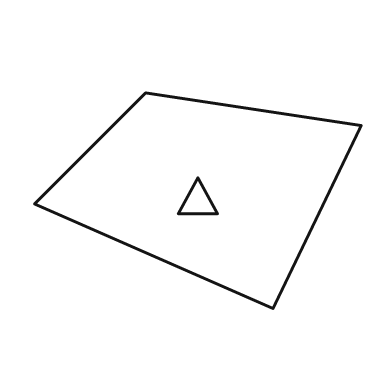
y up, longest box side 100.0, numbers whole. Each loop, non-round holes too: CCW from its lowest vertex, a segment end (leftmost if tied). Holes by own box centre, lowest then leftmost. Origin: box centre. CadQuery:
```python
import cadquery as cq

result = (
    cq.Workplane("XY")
    .moveTo(23.0, -33.0)
    .lineTo(50.0, 23.0)
    .lineTo(-16.0, 33.0)
    .lineTo(-50.0, -1.0)
    .close()
    .moveTo(-6.0, -4.0)
    .lineTo(6.0, -4.0)
    .lineTo(0.0, 7.0)
    .close()
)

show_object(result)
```